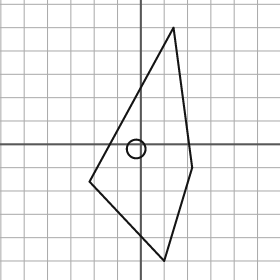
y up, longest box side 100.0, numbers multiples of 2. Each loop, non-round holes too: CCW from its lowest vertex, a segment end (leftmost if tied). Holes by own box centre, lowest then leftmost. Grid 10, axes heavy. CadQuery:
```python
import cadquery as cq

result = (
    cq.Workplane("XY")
    .moveTo(10.0, -50.0)
    .lineTo(22.0, -10.0)
    .lineTo(14.0, 50.0)
    .lineTo(-22.0, -16.0)
    .close()
    .moveTo(-2.0, -2.0)
    .circle(4.0)
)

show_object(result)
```